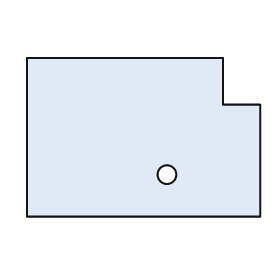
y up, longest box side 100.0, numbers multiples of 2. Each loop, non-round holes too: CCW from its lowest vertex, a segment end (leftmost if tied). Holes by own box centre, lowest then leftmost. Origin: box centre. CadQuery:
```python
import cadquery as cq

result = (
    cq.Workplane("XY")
    .moveTo(-50.0, -34.0)
    .lineTo(50.0, -34.0)
    .lineTo(50.0, 14.0)
    .lineTo(34.0, 14.0)
    .lineTo(34.0, 34.0)
    .lineTo(-50.0, 34.0)
    .close()
    .moveTo(10.0, -16.0)
    .circle(4.0)
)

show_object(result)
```